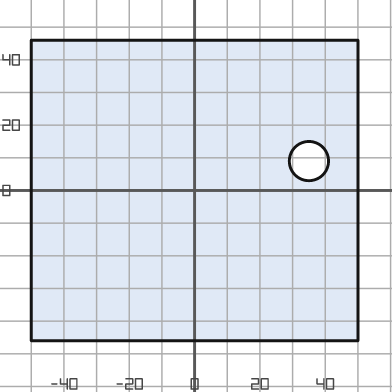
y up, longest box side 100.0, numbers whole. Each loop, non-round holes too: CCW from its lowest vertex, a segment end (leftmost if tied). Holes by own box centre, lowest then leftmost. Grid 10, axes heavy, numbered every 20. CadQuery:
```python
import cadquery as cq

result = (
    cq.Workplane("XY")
    .moveTo(-50.0, -46.0)
    .lineTo(50.0, -46.0)
    .lineTo(50.0, 46.0)
    .lineTo(-50.0, 46.0)
    .close()
    .moveTo(35.0, 9.0)
    .circle(6.0)
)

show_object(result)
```